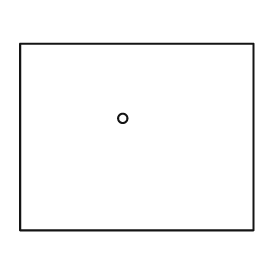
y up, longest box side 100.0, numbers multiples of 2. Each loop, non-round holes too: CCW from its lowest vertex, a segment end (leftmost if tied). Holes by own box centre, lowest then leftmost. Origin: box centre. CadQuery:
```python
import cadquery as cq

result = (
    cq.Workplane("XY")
    .moveTo(-50.0, -40.0)
    .lineTo(50.0, -40.0)
    .lineTo(50.0, 40.0)
    .lineTo(-50.0, 40.0)
    .close()
    .moveTo(-6.0, 8.0)
    .circle(2.0)
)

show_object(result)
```